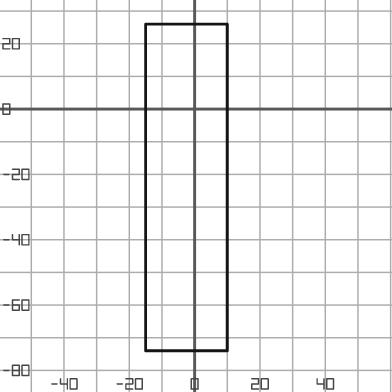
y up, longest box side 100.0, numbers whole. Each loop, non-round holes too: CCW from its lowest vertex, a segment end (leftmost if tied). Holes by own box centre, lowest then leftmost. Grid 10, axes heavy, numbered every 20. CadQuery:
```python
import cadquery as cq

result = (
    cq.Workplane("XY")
    .moveTo(-15.0, -74.0)
    .lineTo(10.0, -74.0)
    .lineTo(10.0, 26.0)
    .lineTo(-15.0, 26.0)
    .close()
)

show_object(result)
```